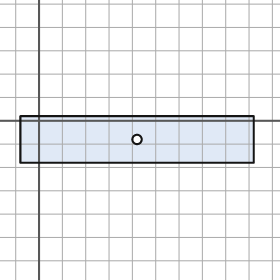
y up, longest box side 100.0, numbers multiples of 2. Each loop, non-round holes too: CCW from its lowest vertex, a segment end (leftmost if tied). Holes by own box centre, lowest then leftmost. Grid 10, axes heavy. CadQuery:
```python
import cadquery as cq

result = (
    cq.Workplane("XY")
    .moveTo(-8.0, -18.0)
    .lineTo(92.0, -18.0)
    .lineTo(92.0, 2.0)
    .lineTo(-8.0, 2.0)
    .close()
    .moveTo(42.0, -8.0)
    .circle(2.0)
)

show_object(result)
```